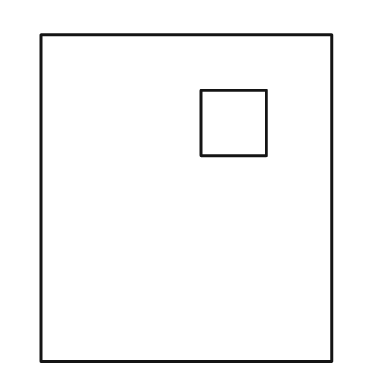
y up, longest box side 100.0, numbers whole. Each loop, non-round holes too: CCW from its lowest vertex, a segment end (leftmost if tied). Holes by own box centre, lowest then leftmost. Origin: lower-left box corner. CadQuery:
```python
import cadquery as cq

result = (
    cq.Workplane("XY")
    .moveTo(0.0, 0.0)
    .lineTo(89.0, 0.0)
    .lineTo(89.0, 100.0)
    .lineTo(0.0, 100.0)
    .close()
    .moveTo(49.0, 63.0)
    .lineTo(69.0, 63.0)
    .lineTo(69.0, 83.0)
    .lineTo(49.0, 83.0)
    .close()
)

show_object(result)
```